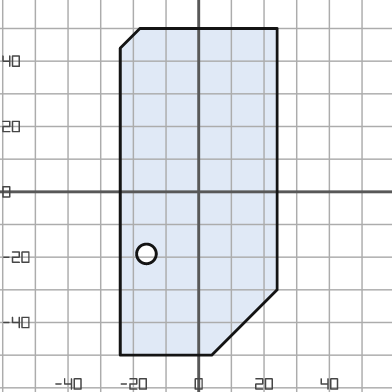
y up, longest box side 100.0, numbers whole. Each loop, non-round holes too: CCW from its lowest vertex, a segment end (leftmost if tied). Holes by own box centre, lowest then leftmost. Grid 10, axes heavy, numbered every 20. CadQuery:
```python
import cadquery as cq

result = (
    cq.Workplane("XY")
    .moveTo(-24.0, -50.0)
    .lineTo(4.0, -50.0)
    .lineTo(24.0, -30.0)
    .lineTo(24.0, 50.0)
    .lineTo(-18.0, 50.0)
    .lineTo(-24.0, 44.0)
    .close()
    .moveTo(-16.0, -19.0)
    .circle(3.0)
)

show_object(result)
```